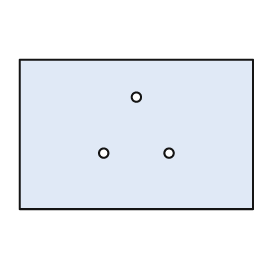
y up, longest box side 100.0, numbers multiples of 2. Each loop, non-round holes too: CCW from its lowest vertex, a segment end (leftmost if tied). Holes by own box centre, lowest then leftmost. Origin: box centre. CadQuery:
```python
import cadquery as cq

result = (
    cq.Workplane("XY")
    .moveTo(-50.0, -32.0)
    .lineTo(50.0, -32.0)
    .lineTo(50.0, 32.0)
    .lineTo(-50.0, 32.0)
    .close()
    .moveTo(-14.0, -8.0)
    .circle(2.0)
    .moveTo(14.0, -8.0)
    .circle(2.0)
    .moveTo(0.0, 16.0)
    .circle(2.0)
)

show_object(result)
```